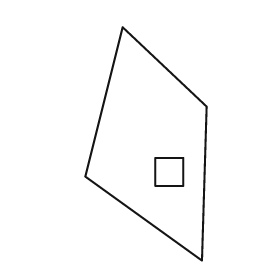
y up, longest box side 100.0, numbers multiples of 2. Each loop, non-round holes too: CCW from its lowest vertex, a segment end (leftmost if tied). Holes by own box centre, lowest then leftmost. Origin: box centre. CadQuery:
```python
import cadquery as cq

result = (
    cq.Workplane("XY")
    .moveTo(24.0, -50.0)
    .lineTo(26.0, 16.0)
    .lineTo(-10.0, 50.0)
    .lineTo(-26.0, -14.0)
    .close()
    .moveTo(4.0, -18.0)
    .lineTo(16.0, -18.0)
    .lineTo(16.0, -6.0)
    .lineTo(4.0, -6.0)
    .close()
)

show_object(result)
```